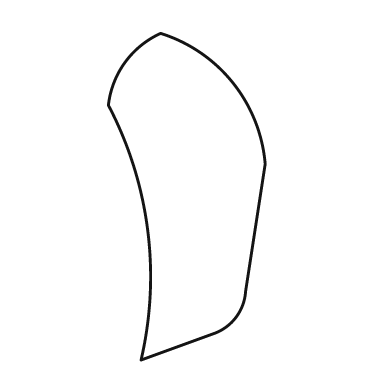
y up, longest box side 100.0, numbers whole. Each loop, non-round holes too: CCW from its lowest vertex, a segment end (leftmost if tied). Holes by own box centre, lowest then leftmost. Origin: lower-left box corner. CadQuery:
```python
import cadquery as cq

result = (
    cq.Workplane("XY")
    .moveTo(10.0, 0.0)
    .lineTo(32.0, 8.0)
    .threePointArc((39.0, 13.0), (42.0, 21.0))
    .lineTo(48.0, 60.0)
    .threePointArc((38.0, 85.0), (16.0, 100.0))
    .threePointArc((5.0, 91.0), (0.0, 78.0))
    .threePointArc((12.0, 40.0), (10.0, 0.0))
    .close()
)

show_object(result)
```